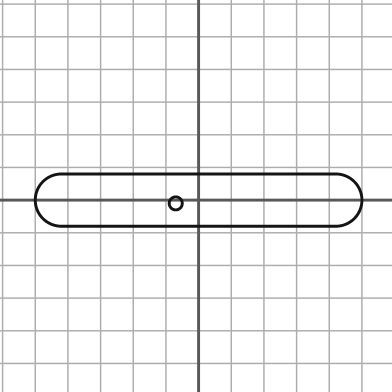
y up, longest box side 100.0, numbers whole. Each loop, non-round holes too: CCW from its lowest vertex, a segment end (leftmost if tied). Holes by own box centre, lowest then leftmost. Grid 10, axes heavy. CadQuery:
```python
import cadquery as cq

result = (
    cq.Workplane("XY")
    .moveTo(-42.0, -8.0)
    .lineTo(42.0, -8.0)
    .threePointArc((50.0, 0.0), (42.0, 8.0))
    .lineTo(-42.0, 8.0)
    .threePointArc((-50.0, 0.0), (-42.0, -8.0))
    .close()
    .moveTo(-7.0, -1.0)
    .circle(2.0)
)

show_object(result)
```